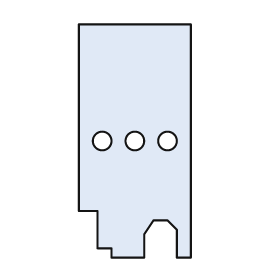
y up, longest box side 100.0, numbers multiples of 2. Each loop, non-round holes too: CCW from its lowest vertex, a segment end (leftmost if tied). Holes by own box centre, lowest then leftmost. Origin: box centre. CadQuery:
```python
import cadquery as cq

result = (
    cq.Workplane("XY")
    .moveTo(-10.0, -50.0)
    .lineTo(4.0, -50.0)
    .lineTo(4.0, -40.0)
    .lineTo(8.0, -34.0)
    .lineTo(14.0, -34.0)
    .lineTo(18.0, -38.0)
    .lineTo(18.0, -50.0)
    .lineTo(24.0, -50.0)
    .lineTo(24.0, 50.0)
    .lineTo(-24.0, 50.0)
    .lineTo(-24.0, -30.0)
    .lineTo(-16.0, -30.0)
    .lineTo(-16.0, -46.0)
    .lineTo(-10.0, -46.0)
    .close()
    .moveTo(-14.0, 0.0)
    .circle(4.0)
    .moveTo(0.0, 0.0)
    .circle(4.0)
    .moveTo(14.0, 0.0)
    .circle(4.0)
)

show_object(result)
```